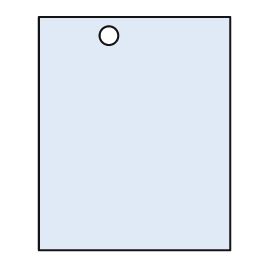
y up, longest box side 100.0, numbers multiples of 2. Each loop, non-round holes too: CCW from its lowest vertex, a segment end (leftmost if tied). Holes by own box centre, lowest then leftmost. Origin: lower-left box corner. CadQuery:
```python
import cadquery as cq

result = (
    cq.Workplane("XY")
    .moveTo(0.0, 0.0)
    .lineTo(82.0, 0.0)
    .lineTo(82.0, 100.0)
    .lineTo(0.0, 100.0)
    .close()
    .moveTo(30.0, 92.0)
    .circle(4.0)
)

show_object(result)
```